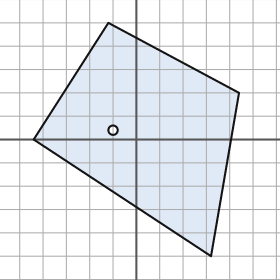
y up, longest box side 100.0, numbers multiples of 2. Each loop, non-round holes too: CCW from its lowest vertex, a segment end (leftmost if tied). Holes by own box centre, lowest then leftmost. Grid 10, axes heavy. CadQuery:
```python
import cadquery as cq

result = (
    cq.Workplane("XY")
    .moveTo(32.0, -50.0)
    .lineTo(44.0, 20.0)
    .lineTo(-12.0, 50.0)
    .lineTo(-44.0, 0.0)
    .close()
    .moveTo(-10.0, 4.0)
    .circle(2.0)
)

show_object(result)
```